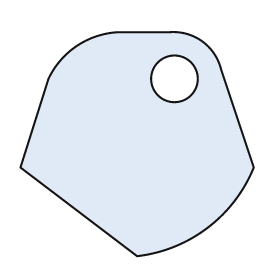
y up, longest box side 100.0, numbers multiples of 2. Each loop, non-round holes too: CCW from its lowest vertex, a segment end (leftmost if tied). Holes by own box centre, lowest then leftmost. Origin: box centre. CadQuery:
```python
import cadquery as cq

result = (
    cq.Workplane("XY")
    .moveTo(0.0, -48.0)
    .threePointArc((30.0, -36.0), (50.0, -10.0))
    .lineTo(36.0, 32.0)
    .threePointArc((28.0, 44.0), (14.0, 48.0))
    .lineTo(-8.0, 48.0)
    .threePointArc((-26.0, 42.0), (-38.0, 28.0))
    .lineTo(-50.0, -10.0)
    .close()
    .moveTo(16.0, 28.0)
    .circle(10.0)
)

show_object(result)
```